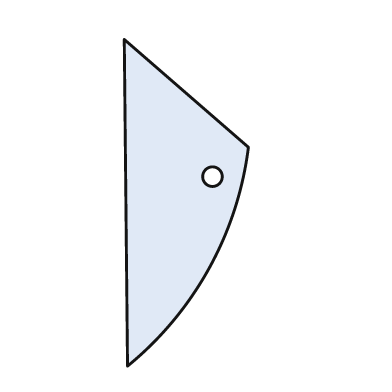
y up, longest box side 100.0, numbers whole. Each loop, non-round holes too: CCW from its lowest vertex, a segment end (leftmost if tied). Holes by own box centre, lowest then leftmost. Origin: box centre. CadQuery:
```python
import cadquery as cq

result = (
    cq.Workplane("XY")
    .moveTo(-18.0, -50.0)
    .threePointArc((7.0, -20.0), (19.0, 17.0))
    .lineTo(-19.0, 50.0)
    .close()
    .moveTo(8.0, 8.0)
    .circle(3.0)
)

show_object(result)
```